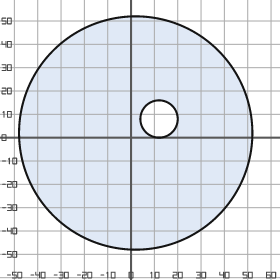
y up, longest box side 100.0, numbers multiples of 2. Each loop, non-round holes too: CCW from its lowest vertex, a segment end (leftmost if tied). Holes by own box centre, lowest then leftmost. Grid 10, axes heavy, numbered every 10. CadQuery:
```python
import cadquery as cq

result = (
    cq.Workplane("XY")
    .moveTo(2.0, 2.0)
    .circle(50.0)
    .moveTo(12.0, 8.0)
    .circle(8.0)
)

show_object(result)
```